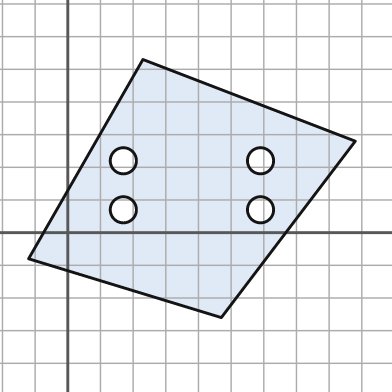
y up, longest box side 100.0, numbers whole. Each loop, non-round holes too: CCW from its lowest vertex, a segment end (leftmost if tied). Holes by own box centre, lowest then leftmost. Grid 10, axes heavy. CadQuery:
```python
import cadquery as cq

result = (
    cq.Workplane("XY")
    .moveTo(47.0, -26.0)
    .lineTo(88.0, 28.0)
    .lineTo(23.0, 53.0)
    .lineTo(-12.0, -8.0)
    .close()
    .moveTo(17.0, 7.0)
    .circle(4.0)
    .moveTo(59.0, 7.0)
    .circle(4.0)
    .moveTo(17.0, 22.0)
    .circle(4.0)
    .moveTo(59.0, 22.0)
    .circle(4.0)
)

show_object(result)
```